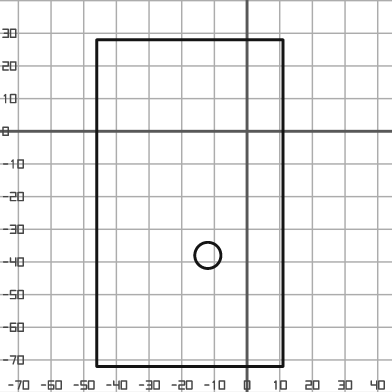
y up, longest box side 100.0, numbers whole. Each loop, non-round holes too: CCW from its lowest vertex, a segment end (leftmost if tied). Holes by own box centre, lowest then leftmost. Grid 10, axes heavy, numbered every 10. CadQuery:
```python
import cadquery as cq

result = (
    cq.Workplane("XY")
    .moveTo(-46.0, -72.0)
    .lineTo(11.0, -72.0)
    .lineTo(11.0, 28.0)
    .lineTo(-46.0, 28.0)
    .close()
    .moveTo(-12.0, -38.0)
    .circle(4.0)
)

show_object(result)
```